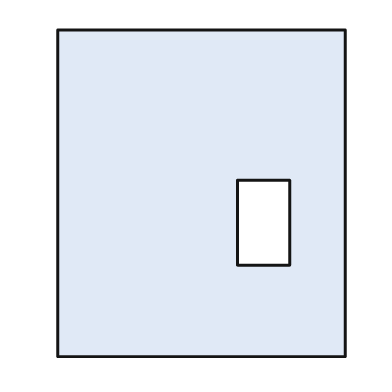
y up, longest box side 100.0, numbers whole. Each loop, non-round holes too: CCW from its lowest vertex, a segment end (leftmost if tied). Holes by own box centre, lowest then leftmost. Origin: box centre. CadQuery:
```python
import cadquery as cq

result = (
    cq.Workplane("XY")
    .moveTo(-44.0, -50.0)
    .lineTo(44.0, -50.0)
    .lineTo(44.0, 50.0)
    .lineTo(-44.0, 50.0)
    .close()
    .moveTo(11.0, -22.0)
    .lineTo(27.0, -22.0)
    .lineTo(27.0, 4.0)
    .lineTo(11.0, 4.0)
    .close()
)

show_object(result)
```